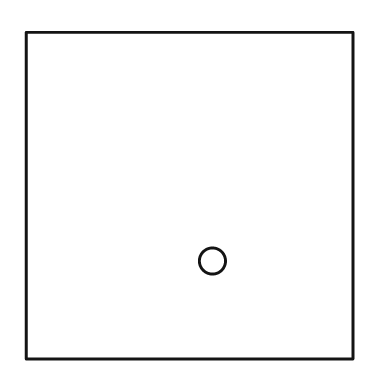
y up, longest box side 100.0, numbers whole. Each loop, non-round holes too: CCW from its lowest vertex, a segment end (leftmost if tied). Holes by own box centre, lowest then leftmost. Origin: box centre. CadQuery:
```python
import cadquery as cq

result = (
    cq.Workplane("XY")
    .moveTo(-50.0, -50.0)
    .lineTo(50.0, -50.0)
    .lineTo(50.0, 50.0)
    .lineTo(-50.0, 50.0)
    .close()
    .moveTo(7.0, -20.0)
    .circle(4.0)
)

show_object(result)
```